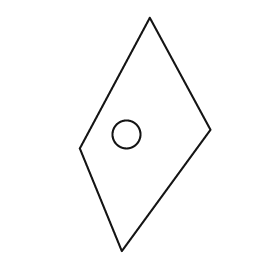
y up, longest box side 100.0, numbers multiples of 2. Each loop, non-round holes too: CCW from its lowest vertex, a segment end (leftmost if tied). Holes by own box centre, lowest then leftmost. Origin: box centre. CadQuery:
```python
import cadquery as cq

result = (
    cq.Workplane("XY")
    .moveTo(-10.0, -50.0)
    .lineTo(28.0, 2.0)
    .lineTo(2.0, 50.0)
    .lineTo(-28.0, -6.0)
    .close()
    .moveTo(-8.0, 0.0)
    .circle(6.0)
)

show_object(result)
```